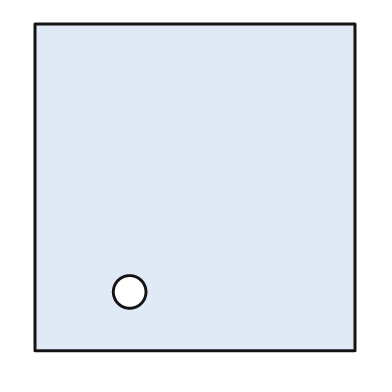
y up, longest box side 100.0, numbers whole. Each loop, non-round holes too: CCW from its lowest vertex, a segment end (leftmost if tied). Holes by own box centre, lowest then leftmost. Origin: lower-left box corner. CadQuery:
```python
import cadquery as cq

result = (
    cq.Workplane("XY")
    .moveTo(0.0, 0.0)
    .lineTo(98.0, 0.0)
    .lineTo(98.0, 100.0)
    .lineTo(0.0, 100.0)
    .close()
    .moveTo(29.0, 18.0)
    .circle(5.0)
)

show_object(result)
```